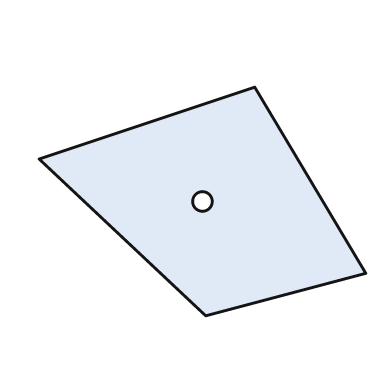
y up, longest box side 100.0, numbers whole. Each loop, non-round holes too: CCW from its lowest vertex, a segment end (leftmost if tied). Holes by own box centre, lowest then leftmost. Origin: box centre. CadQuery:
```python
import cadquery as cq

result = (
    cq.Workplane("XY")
    .moveTo(1.0, -35.0)
    .lineTo(50.0, -22.0)
    .lineTo(16.0, 35.0)
    .lineTo(-50.0, 13.0)
    .close()
    .moveTo(0.0, 0.0)
    .circle(3.0)
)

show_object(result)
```